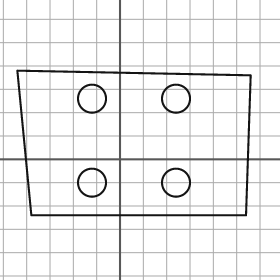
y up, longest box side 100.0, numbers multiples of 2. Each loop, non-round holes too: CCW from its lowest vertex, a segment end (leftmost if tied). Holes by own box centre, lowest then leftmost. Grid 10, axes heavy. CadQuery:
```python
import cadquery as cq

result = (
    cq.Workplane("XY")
    .moveTo(-38.0, -24.0)
    .lineTo(54.0, -24.0)
    .lineTo(56.0, 36.0)
    .lineTo(-44.0, 38.0)
    .close()
    .moveTo(-12.0, -10.0)
    .circle(6.0)
    .moveTo(24.0, -10.0)
    .circle(6.0)
    .moveTo(-12.0, 26.0)
    .circle(6.0)
    .moveTo(24.0, 26.0)
    .circle(6.0)
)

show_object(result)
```